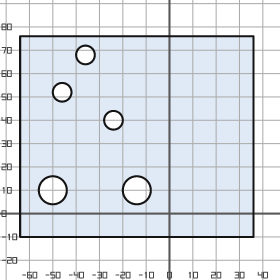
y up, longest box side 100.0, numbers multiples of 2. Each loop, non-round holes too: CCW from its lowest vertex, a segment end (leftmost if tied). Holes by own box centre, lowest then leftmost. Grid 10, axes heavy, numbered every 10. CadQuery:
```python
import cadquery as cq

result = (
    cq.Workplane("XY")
    .moveTo(-64.0, -10.0)
    .lineTo(36.0, -10.0)
    .lineTo(36.0, 76.0)
    .lineTo(-64.0, 76.0)
    .close()
    .moveTo(-50.0, 10.0)
    .circle(6.0)
    .moveTo(-14.0, 10.0)
    .circle(6.0)
    .moveTo(-24.0, 40.0)
    .circle(4.0)
    .moveTo(-46.0, 52.0)
    .circle(4.0)
    .moveTo(-36.0, 68.0)
    .circle(4.0)
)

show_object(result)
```